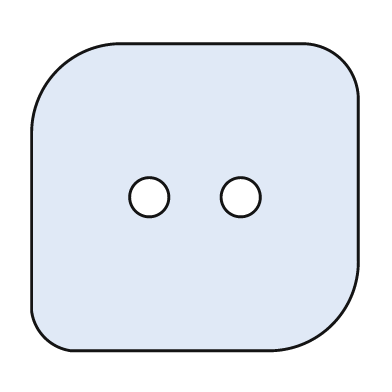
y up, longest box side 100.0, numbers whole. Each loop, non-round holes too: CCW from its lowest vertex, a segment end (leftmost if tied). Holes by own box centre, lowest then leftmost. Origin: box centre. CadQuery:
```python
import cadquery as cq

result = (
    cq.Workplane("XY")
    .moveTo(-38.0, -47.0)
    .lineTo(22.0, -47.0)
    .threePointArc((42.0, -39.0), (50.0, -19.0))
    .lineTo(50.0, 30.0)
    .threePointArc((45.0, 42.0), (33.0, 47.0))
    .lineTo(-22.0, 47.0)
    .threePointArc((-42.0, 39.0), (-50.0, 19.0))
    .lineTo(-50.0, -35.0)
    .threePointArc((-46.0, -43.0), (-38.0, -47.0))
    .close()
    .moveTo(-14.0, 0.0)
    .circle(6.0)
    .moveTo(14.0, 0.0)
    .circle(6.0)
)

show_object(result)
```